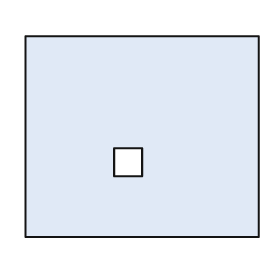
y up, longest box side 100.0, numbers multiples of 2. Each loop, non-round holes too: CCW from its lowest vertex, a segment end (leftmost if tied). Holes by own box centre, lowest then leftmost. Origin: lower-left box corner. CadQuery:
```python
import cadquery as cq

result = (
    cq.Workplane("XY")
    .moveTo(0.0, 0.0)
    .lineTo(100.0, 0.0)
    .lineTo(100.0, 86.0)
    .lineTo(0.0, 86.0)
    .close()
    .moveTo(38.0, 26.0)
    .lineTo(50.0, 26.0)
    .lineTo(50.0, 38.0)
    .lineTo(38.0, 38.0)
    .close()
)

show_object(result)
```